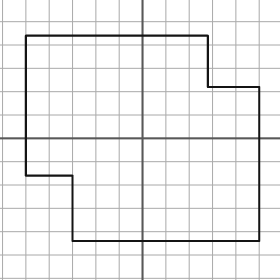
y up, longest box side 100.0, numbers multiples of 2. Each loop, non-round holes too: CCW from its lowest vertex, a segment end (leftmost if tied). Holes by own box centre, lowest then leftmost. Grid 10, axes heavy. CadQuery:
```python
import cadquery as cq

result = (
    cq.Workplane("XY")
    .moveTo(-30.0, -44.0)
    .lineTo(50.0, -44.0)
    .lineTo(50.0, 22.0)
    .lineTo(28.0, 22.0)
    .lineTo(28.0, 44.0)
    .lineTo(-50.0, 44.0)
    .lineTo(-50.0, -16.0)
    .lineTo(-30.0, -16.0)
    .close()
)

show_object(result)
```